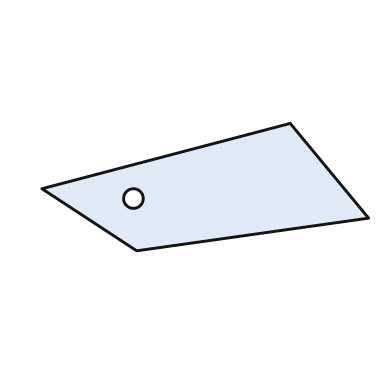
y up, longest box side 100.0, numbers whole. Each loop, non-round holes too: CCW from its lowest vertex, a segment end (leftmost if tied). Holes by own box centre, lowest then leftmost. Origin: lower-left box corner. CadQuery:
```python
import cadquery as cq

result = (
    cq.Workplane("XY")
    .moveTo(29.0, 0.0)
    .lineTo(100.0, 10.0)
    .lineTo(76.0, 39.0)
    .lineTo(0.0, 19.0)
    .close()
    .moveTo(28.0, 16.0)
    .circle(3.0)
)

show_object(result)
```